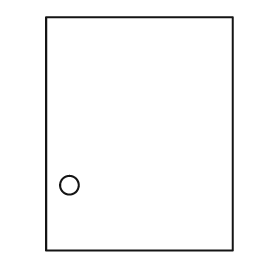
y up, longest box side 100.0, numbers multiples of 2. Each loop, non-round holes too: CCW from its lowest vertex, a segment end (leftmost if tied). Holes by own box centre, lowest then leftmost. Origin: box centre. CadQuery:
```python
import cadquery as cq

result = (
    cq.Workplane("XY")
    .moveTo(-40.0, -50.0)
    .lineTo(40.0, -50.0)
    .lineTo(40.0, 50.0)
    .lineTo(-40.0, 50.0)
    .close()
    .moveTo(-30.0, -22.0)
    .circle(4.0)
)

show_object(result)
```